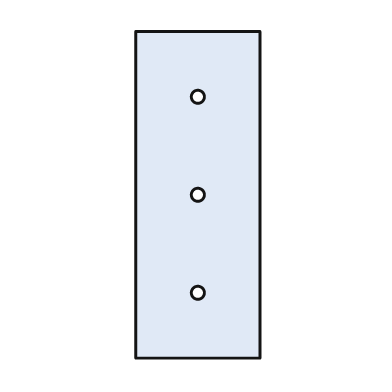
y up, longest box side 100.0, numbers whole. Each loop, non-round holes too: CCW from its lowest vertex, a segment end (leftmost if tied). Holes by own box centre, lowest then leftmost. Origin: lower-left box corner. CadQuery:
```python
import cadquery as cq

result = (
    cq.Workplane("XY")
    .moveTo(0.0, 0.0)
    .lineTo(38.0, 0.0)
    .lineTo(38.0, 100.0)
    .lineTo(0.0, 100.0)
    .close()
    .moveTo(19.0, 20.0)
    .circle(2.0)
    .moveTo(19.0, 50.0)
    .circle(2.0)
    .moveTo(19.0, 80.0)
    .circle(2.0)
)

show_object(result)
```